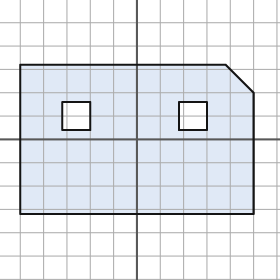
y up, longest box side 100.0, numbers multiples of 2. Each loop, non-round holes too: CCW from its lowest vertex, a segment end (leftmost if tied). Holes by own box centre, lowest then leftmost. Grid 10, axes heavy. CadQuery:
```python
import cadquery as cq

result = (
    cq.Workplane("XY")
    .moveTo(-50.0, -32.0)
    .lineTo(50.0, -32.0)
    .lineTo(50.0, 20.0)
    .lineTo(38.0, 32.0)
    .lineTo(-50.0, 32.0)
    .close()
    .moveTo(-32.0, 4.0)
    .lineTo(-20.0, 4.0)
    .lineTo(-20.0, 16.0)
    .lineTo(-32.0, 16.0)
    .close()
    .moveTo(18.0, 4.0)
    .lineTo(30.0, 4.0)
    .lineTo(30.0, 16.0)
    .lineTo(18.0, 16.0)
    .close()
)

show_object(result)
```